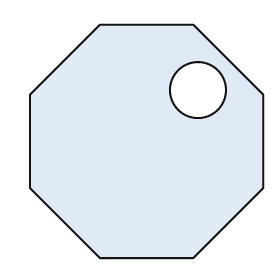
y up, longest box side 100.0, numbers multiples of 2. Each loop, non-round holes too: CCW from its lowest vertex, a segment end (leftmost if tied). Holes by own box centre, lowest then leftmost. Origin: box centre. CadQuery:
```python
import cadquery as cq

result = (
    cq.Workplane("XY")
    .moveTo(-20.0, -50.0)
    .lineTo(20.0, -50.0)
    .lineTo(50.0, -20.0)
    .lineTo(50.0, 20.0)
    .lineTo(20.0, 50.0)
    .lineTo(-20.0, 50.0)
    .lineTo(-50.0, 20.0)
    .lineTo(-50.0, -20.0)
    .close()
    .moveTo(22.0, 22.0)
    .circle(12.0)
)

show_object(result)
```